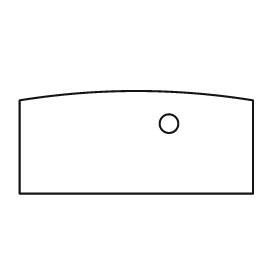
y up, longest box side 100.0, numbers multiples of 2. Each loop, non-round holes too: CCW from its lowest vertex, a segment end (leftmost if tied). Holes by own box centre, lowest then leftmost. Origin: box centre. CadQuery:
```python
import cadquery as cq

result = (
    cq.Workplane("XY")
    .moveTo(-50.0, -22.0)
    .lineTo(50.0, -22.0)
    .lineTo(50.0, 18.0)
    .threePointArc((0.0, 22.0), (-50.0, 18.0))
    .close()
    .moveTo(14.0, 8.0)
    .circle(4.0)
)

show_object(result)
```